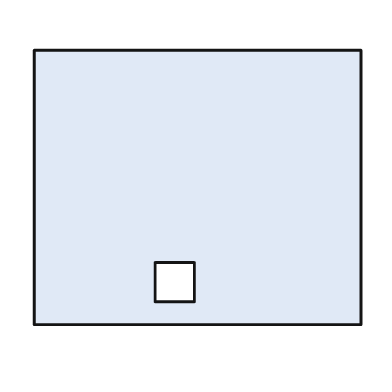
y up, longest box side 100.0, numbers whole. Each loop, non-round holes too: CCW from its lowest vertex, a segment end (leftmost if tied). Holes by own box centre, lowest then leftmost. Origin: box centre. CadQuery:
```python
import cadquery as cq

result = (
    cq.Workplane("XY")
    .moveTo(-50.0, -42.0)
    .lineTo(50.0, -42.0)
    .lineTo(50.0, 42.0)
    .lineTo(-50.0, 42.0)
    .close()
    .moveTo(-13.0, -35.0)
    .lineTo(-1.0, -35.0)
    .lineTo(-1.0, -23.0)
    .lineTo(-13.0, -23.0)
    .close()
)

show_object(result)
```